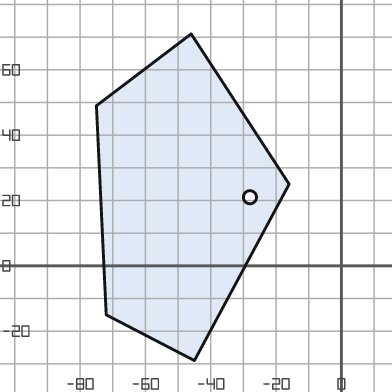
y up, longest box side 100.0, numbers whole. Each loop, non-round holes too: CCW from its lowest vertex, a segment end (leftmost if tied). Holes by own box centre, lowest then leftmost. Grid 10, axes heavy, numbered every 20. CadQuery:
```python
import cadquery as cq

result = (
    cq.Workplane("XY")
    .moveTo(-45.0, -29.0)
    .lineTo(-16.0, 25.0)
    .lineTo(-46.0, 71.0)
    .lineTo(-75.0, 49.0)
    .lineTo(-72.0, -15.0)
    .close()
    .moveTo(-28.0, 21.0)
    .circle(2.0)
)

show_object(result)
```